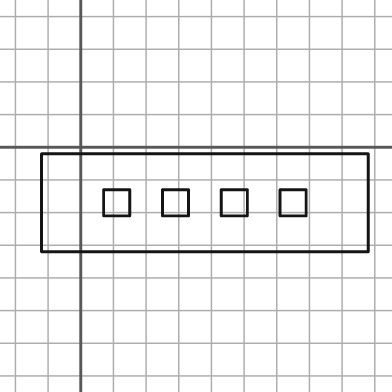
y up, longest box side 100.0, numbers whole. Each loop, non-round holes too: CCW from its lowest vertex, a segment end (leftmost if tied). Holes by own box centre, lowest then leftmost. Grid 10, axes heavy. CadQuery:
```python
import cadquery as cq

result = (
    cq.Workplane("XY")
    .moveTo(-12.0, -32.0)
    .lineTo(88.0, -32.0)
    .lineTo(88.0, -2.0)
    .lineTo(-12.0, -2.0)
    .close()
    .moveTo(7.0, -21.0)
    .lineTo(15.0, -21.0)
    .lineTo(15.0, -13.0)
    .lineTo(7.0, -13.0)
    .close()
    .moveTo(25.0, -21.0)
    .lineTo(33.0, -21.0)
    .lineTo(33.0, -13.0)
    .lineTo(25.0, -13.0)
    .close()
    .moveTo(43.0, -21.0)
    .lineTo(51.0, -21.0)
    .lineTo(51.0, -13.0)
    .lineTo(43.0, -13.0)
    .close()
    .moveTo(61.0, -21.0)
    .lineTo(69.0, -21.0)
    .lineTo(69.0, -13.0)
    .lineTo(61.0, -13.0)
    .close()
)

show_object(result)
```